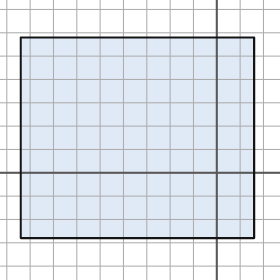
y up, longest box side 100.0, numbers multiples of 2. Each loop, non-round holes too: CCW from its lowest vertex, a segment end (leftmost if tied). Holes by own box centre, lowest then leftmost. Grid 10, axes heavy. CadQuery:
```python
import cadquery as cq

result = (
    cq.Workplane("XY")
    .moveTo(-84.0, -28.0)
    .lineTo(16.0, -28.0)
    .lineTo(16.0, 58.0)
    .lineTo(-84.0, 58.0)
    .close()
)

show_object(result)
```